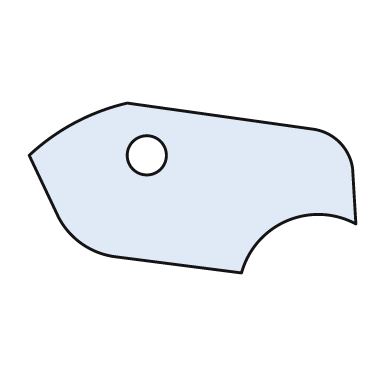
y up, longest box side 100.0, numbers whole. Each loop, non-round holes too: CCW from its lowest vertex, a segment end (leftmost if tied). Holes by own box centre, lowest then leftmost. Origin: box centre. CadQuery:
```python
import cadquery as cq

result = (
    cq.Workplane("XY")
    .moveTo(15.0, -26.0)
    .threePointArc((29.0, -10.0), (50.0, -11.0))
    .lineTo(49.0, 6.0)
    .threePointArc((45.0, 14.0), (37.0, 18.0))
    .lineTo(-20.0, 26.0)
    .threePointArc((-36.0, 20.0), (-50.0, 10.0))
    .lineTo(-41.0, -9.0)
    .threePointArc((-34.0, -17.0), (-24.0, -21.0))
    .close()
    .moveTo(-14.0, 10.0)
    .circle(6.0)
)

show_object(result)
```